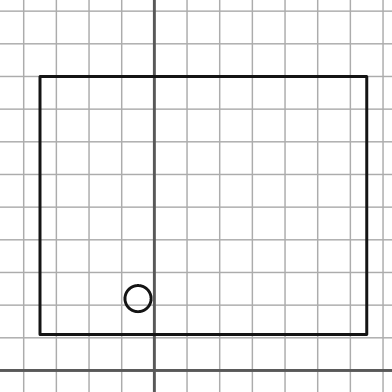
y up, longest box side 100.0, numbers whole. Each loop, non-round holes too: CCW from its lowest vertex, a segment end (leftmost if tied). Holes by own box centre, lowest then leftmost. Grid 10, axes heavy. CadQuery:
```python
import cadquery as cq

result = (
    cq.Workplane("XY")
    .moveTo(-35.0, 11.0)
    .lineTo(65.0, 11.0)
    .lineTo(65.0, 90.0)
    .lineTo(-35.0, 90.0)
    .close()
    .moveTo(-5.0, 22.0)
    .circle(4.0)
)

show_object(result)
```